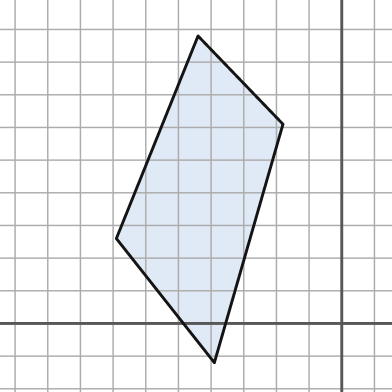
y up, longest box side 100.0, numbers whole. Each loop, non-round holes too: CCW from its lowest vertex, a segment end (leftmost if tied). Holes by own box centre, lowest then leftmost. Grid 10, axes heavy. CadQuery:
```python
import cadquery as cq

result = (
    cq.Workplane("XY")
    .moveTo(-39.0, -12.0)
    .lineTo(-18.0, 61.0)
    .lineTo(-44.0, 88.0)
    .lineTo(-69.0, 26.0)
    .close()
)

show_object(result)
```